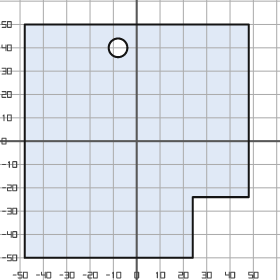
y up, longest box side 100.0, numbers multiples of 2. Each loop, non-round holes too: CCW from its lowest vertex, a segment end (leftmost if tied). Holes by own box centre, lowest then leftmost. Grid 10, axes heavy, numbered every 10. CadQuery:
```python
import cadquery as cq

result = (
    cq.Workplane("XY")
    .moveTo(-48.0, -50.0)
    .lineTo(24.0, -50.0)
    .lineTo(24.0, -24.0)
    .lineTo(48.0, -24.0)
    .lineTo(48.0, 50.0)
    .lineTo(-48.0, 50.0)
    .close()
    .moveTo(-8.0, 40.0)
    .circle(4.0)
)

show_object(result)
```